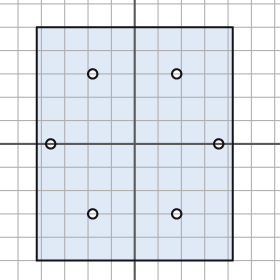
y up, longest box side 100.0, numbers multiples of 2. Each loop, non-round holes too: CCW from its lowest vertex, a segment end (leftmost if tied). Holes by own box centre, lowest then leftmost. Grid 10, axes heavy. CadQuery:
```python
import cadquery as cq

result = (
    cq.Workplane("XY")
    .moveTo(-42.0, -50.0)
    .lineTo(42.0, -50.0)
    .lineTo(42.0, 50.0)
    .lineTo(-42.0, 50.0)
    .close()
    .moveTo(-18.0, -30.0)
    .circle(2.0)
    .moveTo(18.0, -30.0)
    .circle(2.0)
    .moveTo(-36.0, 0.0)
    .circle(2.0)
    .moveTo(36.0, 0.0)
    .circle(2.0)
    .moveTo(-18.0, 30.0)
    .circle(2.0)
    .moveTo(18.0, 30.0)
    .circle(2.0)
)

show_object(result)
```